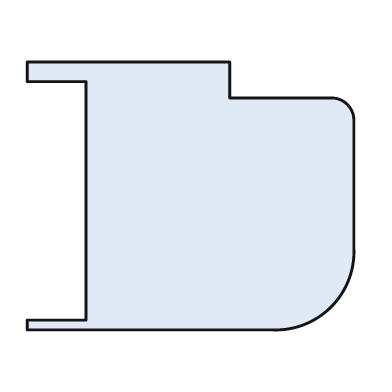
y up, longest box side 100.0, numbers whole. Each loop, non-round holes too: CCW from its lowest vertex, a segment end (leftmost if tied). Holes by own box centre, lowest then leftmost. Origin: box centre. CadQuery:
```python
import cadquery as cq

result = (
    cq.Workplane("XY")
    .moveTo(-50.0, -41.0)
    .lineTo(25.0, -41.0)
    .threePointArc((43.0, -34.0), (50.0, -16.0))
    .lineTo(50.0, 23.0)
    .threePointArc((48.0, 28.0), (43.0, 30.0))
    .lineTo(12.0, 30.0)
    .lineTo(12.0, 41.0)
    .lineTo(-50.0, 41.0)
    .lineTo(-50.0, 35.0)
    .lineTo(-32.0, 35.0)
    .lineTo(-32.0, -38.0)
    .lineTo(-50.0, -38.0)
    .close()
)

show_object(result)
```